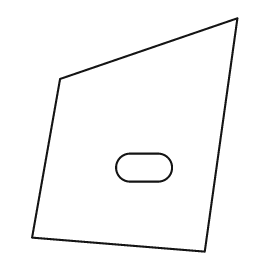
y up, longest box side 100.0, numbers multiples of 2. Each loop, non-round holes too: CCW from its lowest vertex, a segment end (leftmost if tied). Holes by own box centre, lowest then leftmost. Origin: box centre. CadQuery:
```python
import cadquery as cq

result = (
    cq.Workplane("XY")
    .moveTo(30.0, -50.0)
    .lineTo(44.0, 50.0)
    .lineTo(-32.0, 24.0)
    .lineTo(-44.0, -44.0)
    .close()
    .moveTo(-2.0, -20.0)
    .lineTo(10.0, -20.0)
    .threePointArc((16.0, -14.0), (10.0, -8.0))
    .lineTo(-2.0, -8.0)
    .threePointArc((-8.0, -14.0), (-2.0, -20.0))
    .close()
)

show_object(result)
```